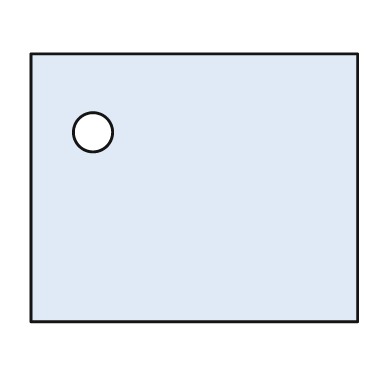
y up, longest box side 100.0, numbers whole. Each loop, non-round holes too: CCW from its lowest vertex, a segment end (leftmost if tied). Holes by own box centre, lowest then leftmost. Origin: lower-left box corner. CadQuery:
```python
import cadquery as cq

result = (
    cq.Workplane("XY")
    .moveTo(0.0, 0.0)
    .lineTo(100.0, 0.0)
    .lineTo(100.0, 82.0)
    .lineTo(0.0, 82.0)
    .close()
    .moveTo(19.0, 58.0)
    .circle(6.0)
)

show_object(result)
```